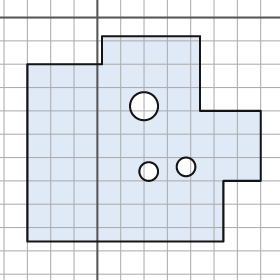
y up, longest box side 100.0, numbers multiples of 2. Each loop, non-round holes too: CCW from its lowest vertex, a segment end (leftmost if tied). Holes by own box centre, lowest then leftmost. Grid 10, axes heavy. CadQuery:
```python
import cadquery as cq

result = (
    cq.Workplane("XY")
    .moveTo(-30.0, -96.0)
    .lineTo(54.0, -96.0)
    .lineTo(54.0, -70.0)
    .lineTo(70.0, -70.0)
    .lineTo(70.0, -40.0)
    .lineTo(44.0, -40.0)
    .lineTo(44.0, -8.0)
    .lineTo(2.0, -8.0)
    .lineTo(2.0, -20.0)
    .lineTo(-30.0, -20.0)
    .close()
    .moveTo(22.0, -66.0)
    .circle(4.0)
    .moveTo(38.0, -64.0)
    .circle(4.0)
    .moveTo(20.0, -38.0)
    .circle(6.0)
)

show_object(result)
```